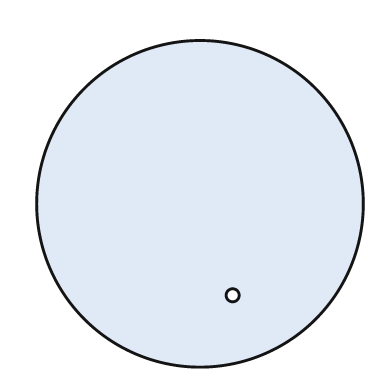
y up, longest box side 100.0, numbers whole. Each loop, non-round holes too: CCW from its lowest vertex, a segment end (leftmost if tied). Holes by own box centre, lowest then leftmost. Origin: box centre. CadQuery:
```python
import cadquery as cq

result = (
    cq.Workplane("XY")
    .moveTo(0.0, 0.0)
    .circle(50.0)
    .moveTo(10.0, -28.0)
    .circle(2.0)
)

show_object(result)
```